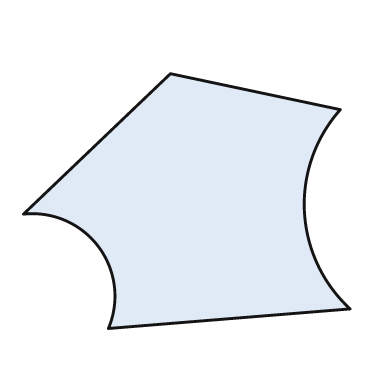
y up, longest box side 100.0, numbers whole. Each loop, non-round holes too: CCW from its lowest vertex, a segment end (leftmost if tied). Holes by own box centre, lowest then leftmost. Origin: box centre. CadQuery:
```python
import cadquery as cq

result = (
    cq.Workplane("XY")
    .moveTo(-24.0, -39.0)
    .lineTo(50.0, -33.0)
    .threePointArc((36.0, -3.0), (47.0, 28.0))
    .lineTo(-5.0, 39.0)
    .lineTo(-50.0, -4.0)
    .threePointArc((-27.0, -14.0), (-24.0, -39.0))
    .close()
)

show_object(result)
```